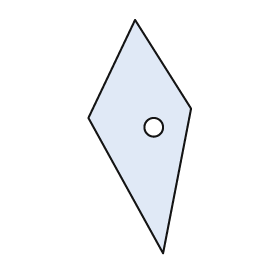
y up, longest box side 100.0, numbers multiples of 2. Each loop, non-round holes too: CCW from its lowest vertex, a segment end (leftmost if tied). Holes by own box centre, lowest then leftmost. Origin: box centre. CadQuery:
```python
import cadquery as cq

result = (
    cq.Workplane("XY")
    .moveTo(10.0, -50.0)
    .lineTo(22.0, 12.0)
    .lineTo(-2.0, 50.0)
    .lineTo(-22.0, 8.0)
    .close()
    .moveTo(6.0, 4.0)
    .circle(4.0)
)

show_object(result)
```